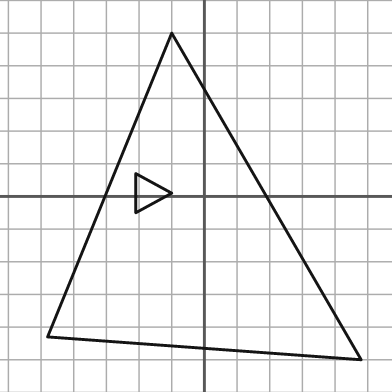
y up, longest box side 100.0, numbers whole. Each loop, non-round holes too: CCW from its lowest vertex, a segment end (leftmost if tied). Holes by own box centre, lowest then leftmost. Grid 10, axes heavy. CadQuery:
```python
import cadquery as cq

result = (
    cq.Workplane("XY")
    .moveTo(48.0, -50.0)
    .lineTo(-10.0, 50.0)
    .lineTo(-48.0, -43.0)
    .close()
    .moveTo(-21.0, -5.0)
    .lineTo(-10.0, 1.0)
    .lineTo(-21.0, 7.0)
    .close()
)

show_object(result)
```